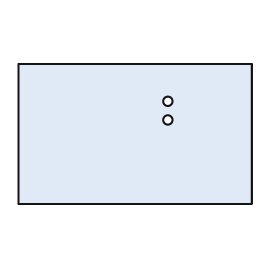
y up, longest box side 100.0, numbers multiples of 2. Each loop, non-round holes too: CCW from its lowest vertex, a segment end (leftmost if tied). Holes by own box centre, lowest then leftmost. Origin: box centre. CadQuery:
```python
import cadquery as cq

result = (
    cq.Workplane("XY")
    .moveTo(-50.0, -30.0)
    .lineTo(50.0, -30.0)
    .lineTo(50.0, 30.0)
    .lineTo(-50.0, 30.0)
    .close()
    .moveTo(14.0, 6.0)
    .circle(2.0)
    .moveTo(14.0, 14.0)
    .circle(2.0)
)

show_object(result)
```